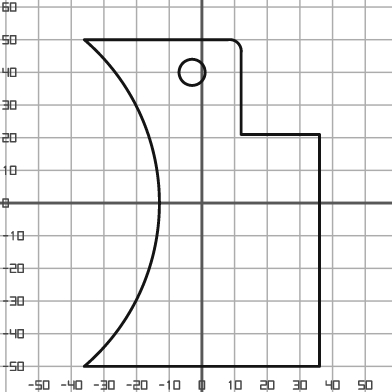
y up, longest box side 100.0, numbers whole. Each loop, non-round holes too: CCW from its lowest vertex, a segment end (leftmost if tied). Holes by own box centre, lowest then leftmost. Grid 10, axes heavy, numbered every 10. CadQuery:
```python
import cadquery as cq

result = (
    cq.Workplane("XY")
    .moveTo(-36.0, -50.0)
    .lineTo(36.0, -50.0)
    .lineTo(36.0, 21.0)
    .lineTo(12.0, 21.0)
    .lineTo(12.0, 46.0)
    .threePointArc((11.0, 49.0), (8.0, 50.0))
    .lineTo(-36.0, 50.0)
    .threePointArc((-13.0, 0.0), (-36.0, -50.0))
    .close()
    .moveTo(-3.0, 40.0)
    .circle(4.0)
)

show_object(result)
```